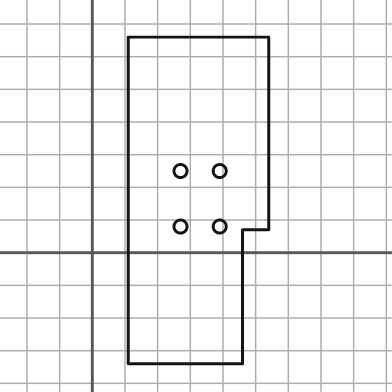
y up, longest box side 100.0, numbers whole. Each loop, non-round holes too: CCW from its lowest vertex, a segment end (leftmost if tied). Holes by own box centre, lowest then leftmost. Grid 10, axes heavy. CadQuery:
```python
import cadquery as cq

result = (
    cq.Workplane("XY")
    .moveTo(11.0, -34.0)
    .lineTo(46.0, -34.0)
    .lineTo(46.0, 7.0)
    .lineTo(54.0, 7.0)
    .lineTo(54.0, 66.0)
    .lineTo(11.0, 66.0)
    .close()
    .moveTo(27.0, 8.0)
    .circle(2.0)
    .moveTo(39.0, 8.0)
    .circle(2.0)
    .moveTo(27.0, 25.0)
    .circle(2.0)
    .moveTo(39.0, 25.0)
    .circle(2.0)
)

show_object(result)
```